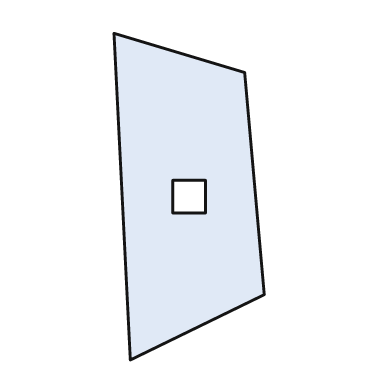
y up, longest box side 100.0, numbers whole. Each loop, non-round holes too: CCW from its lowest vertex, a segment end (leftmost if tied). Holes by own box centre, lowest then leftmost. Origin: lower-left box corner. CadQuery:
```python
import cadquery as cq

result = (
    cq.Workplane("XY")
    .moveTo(5.0, 0.0)
    .lineTo(46.0, 20.0)
    .lineTo(40.0, 88.0)
    .lineTo(0.0, 100.0)
    .close()
    .moveTo(18.0, 45.0)
    .lineTo(28.0, 45.0)
    .lineTo(28.0, 55.0)
    .lineTo(18.0, 55.0)
    .close()
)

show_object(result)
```